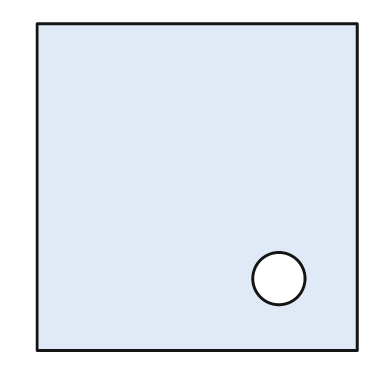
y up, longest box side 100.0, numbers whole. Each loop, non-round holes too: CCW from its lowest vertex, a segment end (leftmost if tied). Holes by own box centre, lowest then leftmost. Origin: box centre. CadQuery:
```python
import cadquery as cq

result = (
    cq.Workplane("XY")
    .moveTo(-49.0, -50.0)
    .lineTo(49.0, -50.0)
    .lineTo(49.0, 50.0)
    .lineTo(-49.0, 50.0)
    .close()
    .moveTo(25.0, -28.0)
    .circle(8.0)
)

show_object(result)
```